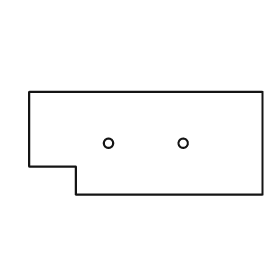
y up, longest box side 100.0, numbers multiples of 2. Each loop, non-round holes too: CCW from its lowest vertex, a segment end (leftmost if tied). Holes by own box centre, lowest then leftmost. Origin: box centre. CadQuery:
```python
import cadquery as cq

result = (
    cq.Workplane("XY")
    .moveTo(-30.0, -22.0)
    .lineTo(50.0, -22.0)
    .lineTo(50.0, 22.0)
    .lineTo(-50.0, 22.0)
    .lineTo(-50.0, -10.0)
    .lineTo(-30.0, -10.0)
    .close()
    .moveTo(-16.0, 0.0)
    .circle(2.0)
    .moveTo(16.0, 0.0)
    .circle(2.0)
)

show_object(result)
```